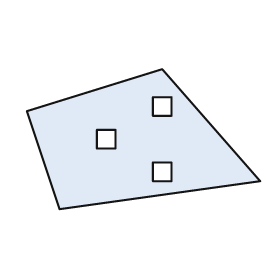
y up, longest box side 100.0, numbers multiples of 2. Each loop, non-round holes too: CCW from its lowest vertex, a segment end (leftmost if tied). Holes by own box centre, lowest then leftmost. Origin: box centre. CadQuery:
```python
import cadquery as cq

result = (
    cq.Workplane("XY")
    .moveTo(-36.0, -30.0)
    .lineTo(50.0, -18.0)
    .lineTo(8.0, 30.0)
    .lineTo(-50.0, 12.0)
    .close()
    .moveTo(4.0, -18.0)
    .lineTo(12.0, -18.0)
    .lineTo(12.0, -10.0)
    .lineTo(4.0, -10.0)
    .close()
    .moveTo(-20.0, -4.0)
    .lineTo(-12.0, -4.0)
    .lineTo(-12.0, 4.0)
    .lineTo(-20.0, 4.0)
    .close()
    .moveTo(4.0, 10.0)
    .lineTo(12.0, 10.0)
    .lineTo(12.0, 18.0)
    .lineTo(4.0, 18.0)
    .close()
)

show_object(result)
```